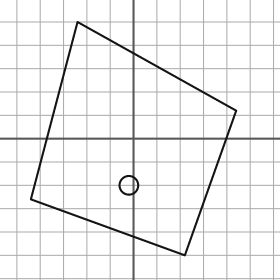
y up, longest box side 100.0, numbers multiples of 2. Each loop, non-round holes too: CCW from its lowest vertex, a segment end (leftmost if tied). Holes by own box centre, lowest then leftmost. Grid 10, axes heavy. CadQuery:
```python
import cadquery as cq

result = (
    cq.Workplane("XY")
    .moveTo(22.0, -50.0)
    .lineTo(44.0, 12.0)
    .lineTo(-24.0, 50.0)
    .lineTo(-44.0, -26.0)
    .close()
    .moveTo(-2.0, -20.0)
    .circle(4.0)
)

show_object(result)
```